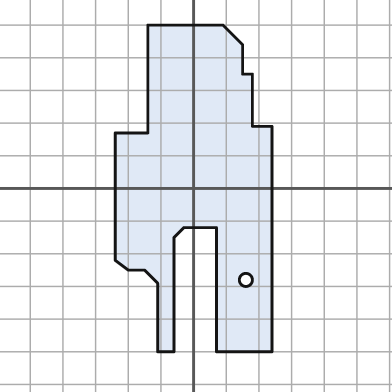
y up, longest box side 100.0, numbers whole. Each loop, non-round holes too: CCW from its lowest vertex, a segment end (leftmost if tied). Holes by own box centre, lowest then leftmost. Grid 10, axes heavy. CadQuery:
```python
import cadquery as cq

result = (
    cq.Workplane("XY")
    .moveTo(-11.0, -50.0)
    .lineTo(-6.0, -50.0)
    .lineTo(-6.0, -15.0)
    .lineTo(-3.0, -12.0)
    .lineTo(7.0, -12.0)
    .lineTo(7.0, -50.0)
    .lineTo(24.0, -50.0)
    .lineTo(24.0, 19.0)
    .lineTo(18.0, 19.0)
    .lineTo(18.0, 35.0)
    .lineTo(15.0, 35.0)
    .lineTo(15.0, 44.0)
    .lineTo(9.0, 50.0)
    .lineTo(-14.0, 50.0)
    .lineTo(-14.0, 17.0)
    .lineTo(-24.0, 17.0)
    .lineTo(-24.0, -22.0)
    .lineTo(-20.0, -25.0)
    .lineTo(-15.0, -25.0)
    .lineTo(-11.0, -29.0)
    .close()
    .moveTo(16.0, -28.0)
    .circle(2.0)
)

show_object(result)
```